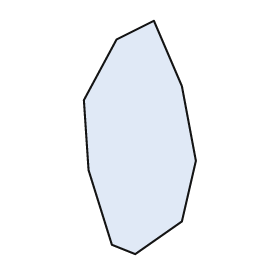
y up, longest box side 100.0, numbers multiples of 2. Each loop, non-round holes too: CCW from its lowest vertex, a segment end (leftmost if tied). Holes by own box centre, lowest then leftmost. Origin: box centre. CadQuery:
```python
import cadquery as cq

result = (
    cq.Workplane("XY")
    .moveTo(-2.0, -50.0)
    .lineTo(18.0, -36.0)
    .lineTo(24.0, -10.0)
    .lineTo(18.0, 22.0)
    .lineTo(6.0, 50.0)
    .lineTo(-10.0, 42.0)
    .lineTo(-24.0, 16.0)
    .lineTo(-22.0, -14.0)
    .lineTo(-12.0, -46.0)
    .close()
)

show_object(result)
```